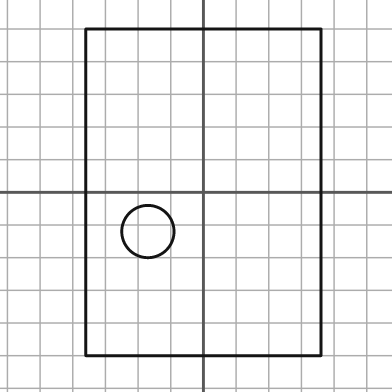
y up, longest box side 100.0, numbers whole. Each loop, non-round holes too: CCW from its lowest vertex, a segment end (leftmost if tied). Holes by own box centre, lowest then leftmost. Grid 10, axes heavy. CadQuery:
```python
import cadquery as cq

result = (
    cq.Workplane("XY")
    .moveTo(-36.0, -50.0)
    .lineTo(36.0, -50.0)
    .lineTo(36.0, 50.0)
    .lineTo(-36.0, 50.0)
    .close()
    .moveTo(-17.0, -12.0)
    .circle(8.0)
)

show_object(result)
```